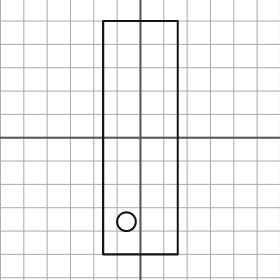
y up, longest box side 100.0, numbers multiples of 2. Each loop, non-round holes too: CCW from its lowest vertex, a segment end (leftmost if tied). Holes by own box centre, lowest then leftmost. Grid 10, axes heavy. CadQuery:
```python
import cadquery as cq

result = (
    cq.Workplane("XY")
    .moveTo(-16.0, -50.0)
    .lineTo(16.0, -50.0)
    .lineTo(16.0, 50.0)
    .lineTo(-16.0, 50.0)
    .close()
    .moveTo(-6.0, -36.0)
    .circle(4.0)
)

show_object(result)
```